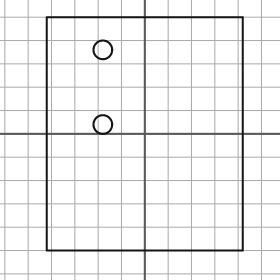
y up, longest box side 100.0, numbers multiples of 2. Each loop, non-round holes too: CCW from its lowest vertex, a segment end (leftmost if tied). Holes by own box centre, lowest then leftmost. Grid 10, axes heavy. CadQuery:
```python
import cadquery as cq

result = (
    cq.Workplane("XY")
    .moveTo(-42.0, -50.0)
    .lineTo(42.0, -50.0)
    .lineTo(42.0, 50.0)
    .lineTo(-42.0, 50.0)
    .close()
    .moveTo(-18.0, 4.0)
    .circle(4.0)
    .moveTo(-18.0, 36.0)
    .circle(4.0)
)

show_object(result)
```